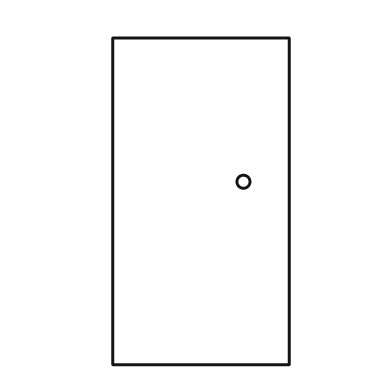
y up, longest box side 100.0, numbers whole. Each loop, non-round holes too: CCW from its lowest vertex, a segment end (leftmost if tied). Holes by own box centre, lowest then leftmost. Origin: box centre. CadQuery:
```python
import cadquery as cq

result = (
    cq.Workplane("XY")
    .moveTo(-27.0, -50.0)
    .lineTo(27.0, -50.0)
    .lineTo(27.0, 50.0)
    .lineTo(-27.0, 50.0)
    .close()
    .moveTo(13.0, 6.0)
    .circle(2.0)
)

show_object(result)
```